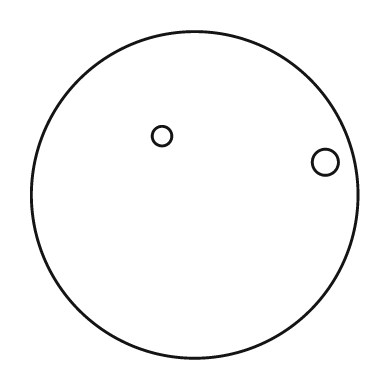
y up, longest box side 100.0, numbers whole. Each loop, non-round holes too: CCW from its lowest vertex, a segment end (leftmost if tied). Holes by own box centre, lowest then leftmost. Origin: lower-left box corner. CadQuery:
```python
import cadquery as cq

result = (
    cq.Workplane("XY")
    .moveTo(50.0, 50.0)
    .circle(50.0)
    .moveTo(90.0, 60.0)
    .circle(4.0)
    .moveTo(40.0, 68.0)
    .circle(3.0)
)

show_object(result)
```